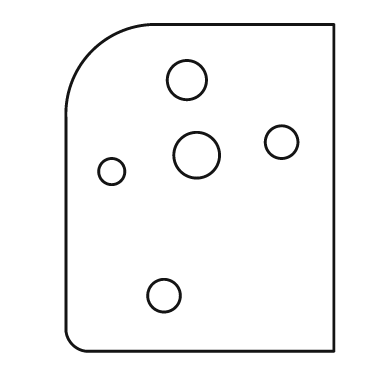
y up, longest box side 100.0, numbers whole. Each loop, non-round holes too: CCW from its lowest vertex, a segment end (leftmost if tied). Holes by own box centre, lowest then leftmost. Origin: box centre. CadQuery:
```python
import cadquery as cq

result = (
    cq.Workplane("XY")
    .moveTo(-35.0, -50.0)
    .lineTo(41.0, -50.0)
    .lineTo(41.0, 50.0)
    .lineTo(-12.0, 50.0)
    .threePointArc((-33.0, 42.0), (-41.0, 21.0))
    .lineTo(-41.0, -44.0)
    .threePointArc((-39.0, -48.0), (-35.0, -50.0))
    .close()
    .moveTo(-11.0, -33.0)
    .circle(5.0)
    .moveTo(-27.0, 5.0)
    .circle(4.0)
    .moveTo(-1.0, 10.0)
    .circle(7.0)
    .moveTo(25.0, 14.0)
    .circle(5.0)
    .moveTo(-4.0, 33.0)
    .circle(6.0)
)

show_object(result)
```